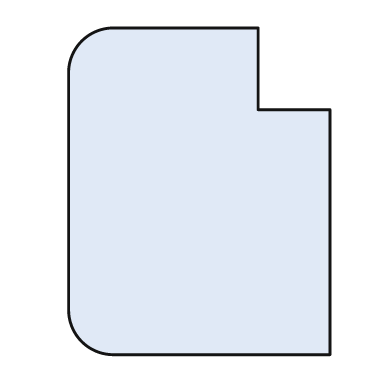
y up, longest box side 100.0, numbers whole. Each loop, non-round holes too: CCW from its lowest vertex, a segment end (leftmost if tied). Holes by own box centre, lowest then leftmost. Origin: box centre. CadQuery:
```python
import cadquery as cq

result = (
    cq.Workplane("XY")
    .moveTo(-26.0, -50.0)
    .lineTo(40.0, -50.0)
    .lineTo(40.0, 25.0)
    .lineTo(18.0, 25.0)
    .lineTo(18.0, 50.0)
    .lineTo(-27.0, 50.0)
    .threePointArc((-36.0, 46.0), (-40.0, 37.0))
    .lineTo(-40.0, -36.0)
    .threePointArc((-36.0, -46.0), (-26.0, -50.0))
    .close()
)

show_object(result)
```